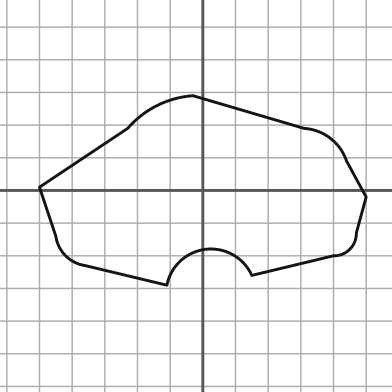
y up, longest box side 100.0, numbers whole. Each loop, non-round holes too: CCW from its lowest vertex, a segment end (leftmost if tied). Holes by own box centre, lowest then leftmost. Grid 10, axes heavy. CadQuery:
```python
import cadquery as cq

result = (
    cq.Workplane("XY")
    .moveTo(-11.0, -29.0)
    .threePointArc((1.0, -18.0), (15.0, -26.0))
    .lineTo(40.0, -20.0)
    .threePointArc((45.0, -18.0), (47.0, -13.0))
    .lineTo(50.0, -2.0)
    .lineTo(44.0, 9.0)
    .threePointArc((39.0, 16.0), (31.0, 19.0))
    .lineTo(-3.0, 29.0)
    .threePointArc((-14.0, 26.0), (-23.0, 19.0))
    .lineTo(-50.0, 1.0)
    .lineTo(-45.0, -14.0)
    .threePointArc((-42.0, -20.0), (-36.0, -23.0))
    .close()
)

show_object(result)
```